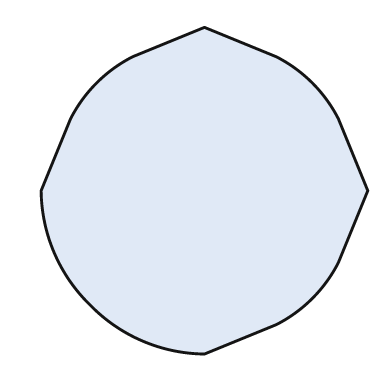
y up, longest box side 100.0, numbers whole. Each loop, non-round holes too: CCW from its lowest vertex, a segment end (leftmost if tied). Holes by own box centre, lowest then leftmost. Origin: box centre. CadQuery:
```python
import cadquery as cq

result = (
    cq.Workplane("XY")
    .moveTo(0.0, -50.0)
    .lineTo(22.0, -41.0)
    .threePointArc((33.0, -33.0), (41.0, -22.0))
    .lineTo(50.0, 0.0)
    .lineTo(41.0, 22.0)
    .threePointArc((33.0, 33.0), (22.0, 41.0))
    .lineTo(0.0, 50.0)
    .lineTo(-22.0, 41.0)
    .threePointArc((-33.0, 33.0), (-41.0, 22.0))
    .lineTo(-50.0, 0.0)
    .threePointArc((-46.0, -19.0), (-35.0, -35.0))
    .threePointArc((-19.0, -46.0), (0.0, -50.0))
    .close()
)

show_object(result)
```